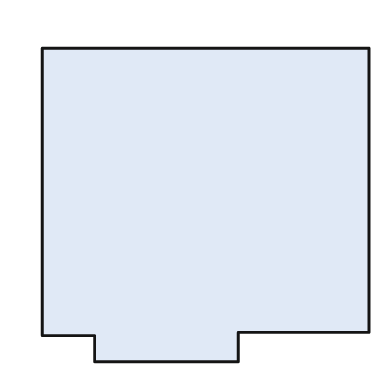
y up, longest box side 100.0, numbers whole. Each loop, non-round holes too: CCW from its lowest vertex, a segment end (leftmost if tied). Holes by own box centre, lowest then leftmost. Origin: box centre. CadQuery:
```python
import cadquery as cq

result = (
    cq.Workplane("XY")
    .moveTo(-34.0, -48.0)
    .lineTo(10.0, -48.0)
    .lineTo(10.0, -39.0)
    .lineTo(50.0, -39.0)
    .lineTo(50.0, 48.0)
    .lineTo(-50.0, 48.0)
    .lineTo(-50.0, -40.0)
    .lineTo(-34.0, -40.0)
    .close()
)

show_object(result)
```